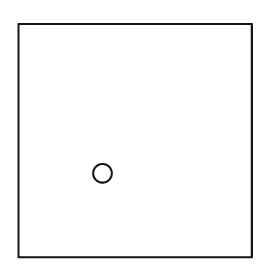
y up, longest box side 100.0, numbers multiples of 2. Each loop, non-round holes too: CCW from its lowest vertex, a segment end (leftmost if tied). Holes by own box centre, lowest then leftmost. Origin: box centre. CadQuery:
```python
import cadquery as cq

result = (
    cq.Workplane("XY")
    .moveTo(-50.0, -50.0)
    .lineTo(50.0, -50.0)
    .lineTo(50.0, 50.0)
    .lineTo(-50.0, 50.0)
    .close()
    .moveTo(-14.0, -14.0)
    .circle(4.0)
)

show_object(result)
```